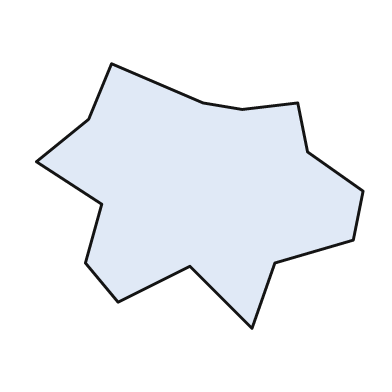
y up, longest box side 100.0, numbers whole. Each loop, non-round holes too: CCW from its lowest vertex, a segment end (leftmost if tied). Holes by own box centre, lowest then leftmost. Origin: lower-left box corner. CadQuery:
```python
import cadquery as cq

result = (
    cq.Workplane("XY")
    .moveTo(66.0, 0.0)
    .lineTo(73.0, 20.0)
    .lineTo(97.0, 27.0)
    .lineTo(100.0, 42.0)
    .lineTo(83.0, 54.0)
    .lineTo(80.0, 69.0)
    .lineTo(63.0, 67.0)
    .lineTo(51.0, 69.0)
    .lineTo(23.0, 81.0)
    .lineTo(16.0, 64.0)
    .lineTo(0.0, 51.0)
    .lineTo(20.0, 38.0)
    .lineTo(15.0, 20.0)
    .lineTo(25.0, 8.0)
    .lineTo(47.0, 19.0)
    .close()
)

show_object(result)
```